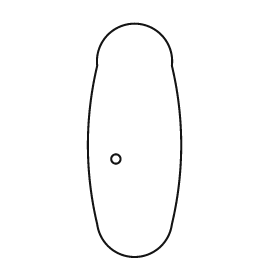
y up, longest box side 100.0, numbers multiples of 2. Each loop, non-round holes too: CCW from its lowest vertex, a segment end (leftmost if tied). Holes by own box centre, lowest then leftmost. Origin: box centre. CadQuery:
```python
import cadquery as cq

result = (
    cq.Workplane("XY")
    .moveTo(-16.0, -36.0)
    .threePointArc((0.0, -50.0), (16.0, -36.0))
    .threePointArc((20.0, -2.0), (16.0, 32.0))
    .threePointArc((0.0, 50.0), (-16.0, 32.0))
    .threePointArc((-20.0, -2.0), (-16.0, -36.0))
    .close()
    .moveTo(-8.0, -8.0)
    .circle(2.0)
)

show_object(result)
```